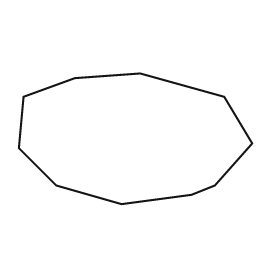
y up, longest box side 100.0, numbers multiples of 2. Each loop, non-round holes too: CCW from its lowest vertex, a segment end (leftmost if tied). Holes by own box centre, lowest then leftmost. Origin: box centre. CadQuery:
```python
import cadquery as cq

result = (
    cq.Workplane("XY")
    .moveTo(-6.0, -28.0)
    .lineTo(24.0, -24.0)
    .lineTo(34.0, -20.0)
    .lineTo(50.0, -2.0)
    .lineTo(38.0, 18.0)
    .lineTo(2.0, 28.0)
    .lineTo(-26.0, 26.0)
    .lineTo(-48.0, 18.0)
    .lineTo(-50.0, -4.0)
    .lineTo(-34.0, -20.0)
    .close()
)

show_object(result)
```